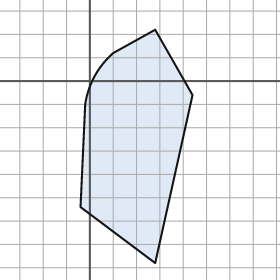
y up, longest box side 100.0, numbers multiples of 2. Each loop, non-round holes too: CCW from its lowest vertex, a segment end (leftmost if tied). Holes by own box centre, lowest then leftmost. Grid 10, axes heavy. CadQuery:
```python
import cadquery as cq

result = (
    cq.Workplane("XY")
    .moveTo(28.0, -78.0)
    .lineTo(44.0, -6.0)
    .lineTo(28.0, 22.0)
    .lineTo(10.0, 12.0)
    .threePointArc((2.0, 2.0), (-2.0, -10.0))
    .lineTo(-4.0, -54.0)
    .close()
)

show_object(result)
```